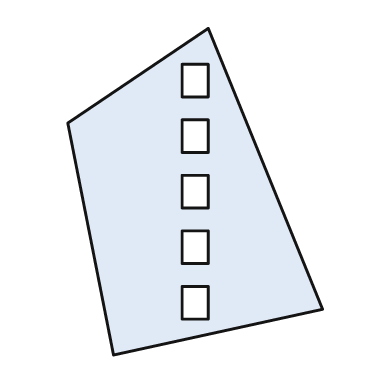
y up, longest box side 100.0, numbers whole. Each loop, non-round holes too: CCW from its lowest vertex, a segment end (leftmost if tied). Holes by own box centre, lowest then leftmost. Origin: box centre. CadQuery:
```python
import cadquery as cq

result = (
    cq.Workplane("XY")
    .moveTo(-25.0, -50.0)
    .lineTo(39.0, -36.0)
    .lineTo(4.0, 50.0)
    .lineTo(-39.0, 21.0)
    .close()
    .moveTo(-4.0, -39.0)
    .lineTo(4.0, -39.0)
    .lineTo(4.0, -29.0)
    .lineTo(-4.0, -29.0)
    .close()
    .moveTo(-4.0, -22.0)
    .lineTo(4.0, -22.0)
    .lineTo(4.0, -12.0)
    .lineTo(-4.0, -12.0)
    .close()
    .moveTo(-4.0, -5.0)
    .lineTo(4.0, -5.0)
    .lineTo(4.0, 5.0)
    .lineTo(-4.0, 5.0)
    .close()
    .moveTo(-4.0, 12.0)
    .lineTo(4.0, 12.0)
    .lineTo(4.0, 22.0)
    .lineTo(-4.0, 22.0)
    .close()
    .moveTo(-4.0, 29.0)
    .lineTo(4.0, 29.0)
    .lineTo(4.0, 39.0)
    .lineTo(-4.0, 39.0)
    .close()
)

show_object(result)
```